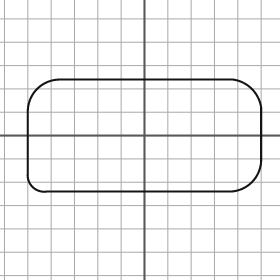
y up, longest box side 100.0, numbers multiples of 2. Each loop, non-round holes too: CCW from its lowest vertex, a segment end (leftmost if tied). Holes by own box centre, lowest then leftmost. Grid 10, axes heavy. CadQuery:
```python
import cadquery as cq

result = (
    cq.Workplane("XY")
    .moveTo(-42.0, -24.0)
    .lineTo(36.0, -24.0)
    .threePointArc((46.0, -20.0), (50.0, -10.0))
    .lineTo(50.0, 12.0)
    .threePointArc((46.0, 20.0), (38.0, 24.0))
    .lineTo(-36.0, 24.0)
    .threePointArc((-46.0, 20.0), (-50.0, 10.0))
    .lineTo(-50.0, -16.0)
    .threePointArc((-48.0, -22.0), (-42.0, -24.0))
    .close()
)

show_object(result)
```